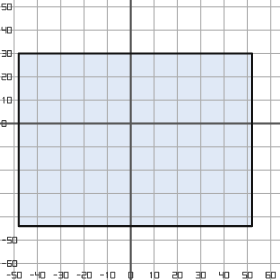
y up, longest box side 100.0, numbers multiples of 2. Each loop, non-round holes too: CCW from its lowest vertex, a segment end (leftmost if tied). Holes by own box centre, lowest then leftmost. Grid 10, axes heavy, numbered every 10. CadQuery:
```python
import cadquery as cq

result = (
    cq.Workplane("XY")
    .moveTo(-48.0, -44.0)
    .lineTo(52.0, -44.0)
    .lineTo(52.0, 30.0)
    .lineTo(-48.0, 30.0)
    .close()
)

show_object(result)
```